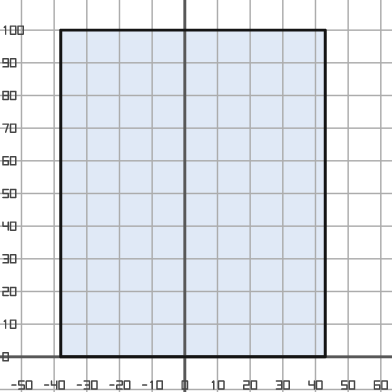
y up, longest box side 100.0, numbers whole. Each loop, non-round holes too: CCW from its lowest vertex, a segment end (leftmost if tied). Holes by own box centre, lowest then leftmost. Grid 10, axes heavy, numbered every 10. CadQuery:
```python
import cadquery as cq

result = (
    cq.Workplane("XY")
    .moveTo(-38.0, 0.0)
    .lineTo(43.0, 0.0)
    .lineTo(43.0, 100.0)
    .lineTo(-38.0, 100.0)
    .close()
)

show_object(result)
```